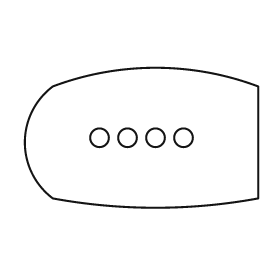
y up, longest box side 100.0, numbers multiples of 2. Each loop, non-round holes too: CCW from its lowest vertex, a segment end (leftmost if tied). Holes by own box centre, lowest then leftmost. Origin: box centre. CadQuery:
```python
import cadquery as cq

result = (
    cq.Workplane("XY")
    .moveTo(-38.0, -26.0)
    .threePointArc((6.0, -30.0), (50.0, -26.0))
    .lineTo(50.0, 22.0)
    .threePointArc((6.0, 30.0), (-38.0, 22.0))
    .threePointArc((-50.0, -2.0), (-38.0, -26.0))
    .close()
    .moveTo(-18.0, 0.0)
    .circle(4.0)
    .moveTo(-6.0, 0.0)
    .circle(4.0)
    .moveTo(6.0, 0.0)
    .circle(4.0)
    .moveTo(18.0, 0.0)
    .circle(4.0)
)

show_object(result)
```